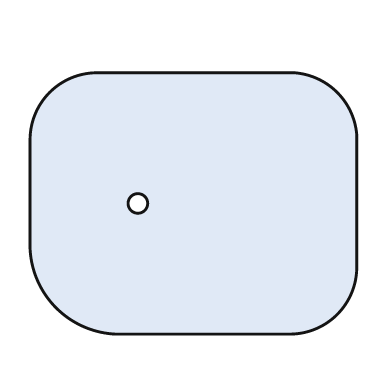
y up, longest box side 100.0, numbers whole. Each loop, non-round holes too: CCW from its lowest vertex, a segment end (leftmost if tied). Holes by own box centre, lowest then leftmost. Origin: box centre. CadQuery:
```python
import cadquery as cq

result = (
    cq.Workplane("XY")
    .moveTo(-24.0, -40.0)
    .lineTo(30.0, -40.0)
    .threePointArc((44.0, -34.0), (50.0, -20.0))
    .lineTo(50.0, 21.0)
    .threePointArc((44.0, 34.0), (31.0, 40.0))
    .lineTo(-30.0, 40.0)
    .threePointArc((-44.0, 34.0), (-50.0, 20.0))
    .lineTo(-50.0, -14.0)
    .threePointArc((-42.0, -32.0), (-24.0, -40.0))
    .close()
    .moveTo(-17.0, 0.0)
    .circle(3.0)
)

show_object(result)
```